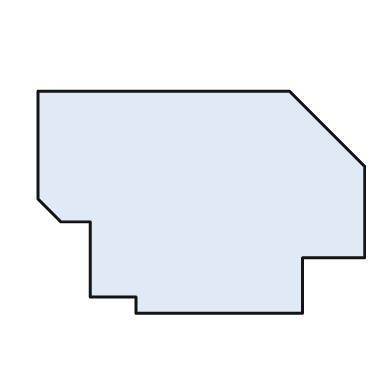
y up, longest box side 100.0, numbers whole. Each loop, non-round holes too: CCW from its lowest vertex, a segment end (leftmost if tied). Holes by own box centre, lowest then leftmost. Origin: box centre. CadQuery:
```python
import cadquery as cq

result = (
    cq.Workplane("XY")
    .moveTo(-20.0, -34.0)
    .lineTo(31.0, -34.0)
    .lineTo(31.0, -17.0)
    .lineTo(50.0, -17.0)
    .lineTo(50.0, 11.0)
    .lineTo(27.0, 34.0)
    .lineTo(-50.0, 34.0)
    .lineTo(-50.0, 1.0)
    .lineTo(-43.0, -6.0)
    .lineTo(-34.0, -6.0)
    .lineTo(-34.0, -29.0)
    .lineTo(-20.0, -29.0)
    .close()
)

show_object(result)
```